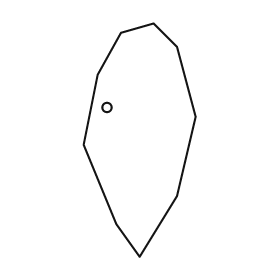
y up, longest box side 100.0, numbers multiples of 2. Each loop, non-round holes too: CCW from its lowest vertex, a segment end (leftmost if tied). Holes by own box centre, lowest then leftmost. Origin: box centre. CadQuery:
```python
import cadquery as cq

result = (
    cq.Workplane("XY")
    .moveTo(0.0, -50.0)
    .lineTo(16.0, -24.0)
    .lineTo(24.0, 10.0)
    .lineTo(16.0, 40.0)
    .lineTo(6.0, 50.0)
    .lineTo(-8.0, 46.0)
    .lineTo(-18.0, 28.0)
    .lineTo(-24.0, -2.0)
    .lineTo(-10.0, -36.0)
    .close()
    .moveTo(-14.0, 14.0)
    .circle(2.0)
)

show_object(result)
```